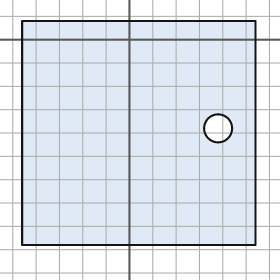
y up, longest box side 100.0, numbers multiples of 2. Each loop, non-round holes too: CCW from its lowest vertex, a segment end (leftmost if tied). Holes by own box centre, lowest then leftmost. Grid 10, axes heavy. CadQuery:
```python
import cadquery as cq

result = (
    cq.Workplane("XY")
    .moveTo(-46.0, -88.0)
    .lineTo(54.0, -88.0)
    .lineTo(54.0, 8.0)
    .lineTo(-46.0, 8.0)
    .close()
    .moveTo(38.0, -38.0)
    .circle(6.0)
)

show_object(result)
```